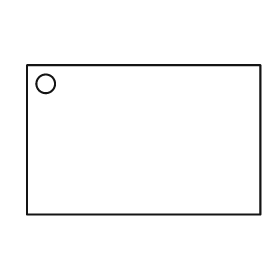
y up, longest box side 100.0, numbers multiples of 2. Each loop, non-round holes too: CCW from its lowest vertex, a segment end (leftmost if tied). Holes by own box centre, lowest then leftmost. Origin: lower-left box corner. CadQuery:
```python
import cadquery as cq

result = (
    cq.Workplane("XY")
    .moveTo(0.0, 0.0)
    .lineTo(100.0, 0.0)
    .lineTo(100.0, 64.0)
    .lineTo(0.0, 64.0)
    .close()
    .moveTo(8.0, 56.0)
    .circle(4.0)
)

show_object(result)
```